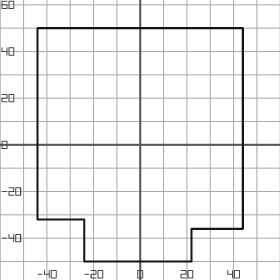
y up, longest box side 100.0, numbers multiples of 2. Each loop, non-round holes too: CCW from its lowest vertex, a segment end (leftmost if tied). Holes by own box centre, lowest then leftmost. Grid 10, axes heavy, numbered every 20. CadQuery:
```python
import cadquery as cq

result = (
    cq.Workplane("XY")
    .moveTo(-24.0, -50.0)
    .lineTo(22.0, -50.0)
    .lineTo(22.0, -36.0)
    .lineTo(44.0, -36.0)
    .lineTo(44.0, 50.0)
    .lineTo(-44.0, 50.0)
    .lineTo(-44.0, -32.0)
    .lineTo(-24.0, -32.0)
    .close()
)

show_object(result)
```